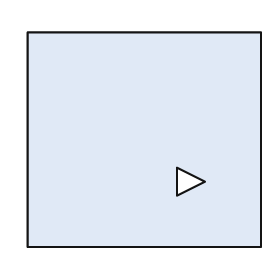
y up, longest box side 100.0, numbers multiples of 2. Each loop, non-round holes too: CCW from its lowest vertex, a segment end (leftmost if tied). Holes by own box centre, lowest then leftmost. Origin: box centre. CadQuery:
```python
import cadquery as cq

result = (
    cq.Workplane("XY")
    .moveTo(-50.0, -46.0)
    .lineTo(50.0, -46.0)
    .lineTo(50.0, 46.0)
    .lineTo(-50.0, 46.0)
    .close()
    .moveTo(14.0, -24.0)
    .lineTo(26.0, -18.0)
    .lineTo(14.0, -12.0)
    .close()
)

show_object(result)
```